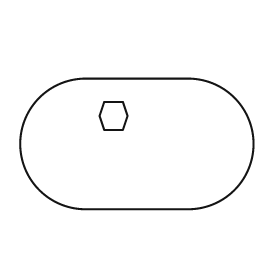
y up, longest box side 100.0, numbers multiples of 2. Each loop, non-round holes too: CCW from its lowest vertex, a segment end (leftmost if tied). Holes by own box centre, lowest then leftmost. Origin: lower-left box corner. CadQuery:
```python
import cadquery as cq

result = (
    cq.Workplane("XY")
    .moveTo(28.0, 0.0)
    .lineTo(72.0, 0.0)
    .threePointArc((100.0, 28.0), (72.0, 56.0))
    .lineTo(28.0, 56.0)
    .threePointArc((0.0, 28.0), (28.0, 0.0))
    .close()
    .moveTo(36.0, 34.0)
    .lineTo(44.0, 34.0)
    .lineTo(46.0, 40.0)
    .lineTo(44.0, 46.0)
    .lineTo(36.0, 46.0)
    .lineTo(34.0, 40.0)
    .close()
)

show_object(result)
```